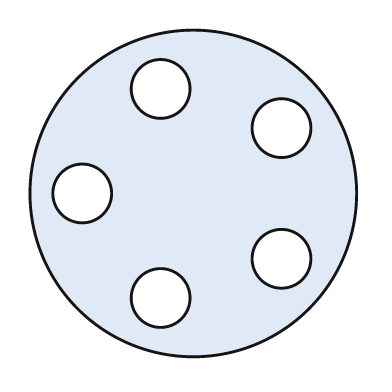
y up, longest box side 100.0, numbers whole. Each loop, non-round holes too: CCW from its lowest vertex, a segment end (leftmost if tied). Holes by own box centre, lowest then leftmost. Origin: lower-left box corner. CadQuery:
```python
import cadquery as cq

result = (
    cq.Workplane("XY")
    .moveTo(50.0, 50.0)
    .circle(50.0)
    .moveTo(40.0, 18.0)
    .circle(9.0)
    .moveTo(77.0, 30.0)
    .circle(9.0)
    .moveTo(16.0, 50.0)
    .circle(9.0)
    .moveTo(77.0, 70.0)
    .circle(9.0)
    .moveTo(40.0, 82.0)
    .circle(9.0)
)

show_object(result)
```